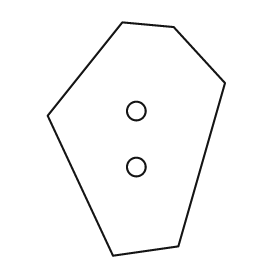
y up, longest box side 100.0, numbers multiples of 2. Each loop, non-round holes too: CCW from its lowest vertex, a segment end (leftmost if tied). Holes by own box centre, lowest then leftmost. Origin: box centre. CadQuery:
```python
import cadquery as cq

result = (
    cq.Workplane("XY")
    .moveTo(-10.0, -50.0)
    .lineTo(18.0, -46.0)
    .lineTo(38.0, 24.0)
    .lineTo(16.0, 48.0)
    .lineTo(-6.0, 50.0)
    .lineTo(-38.0, 10.0)
    .close()
    .moveTo(0.0, -12.0)
    .circle(4.0)
    .moveTo(0.0, 12.0)
    .circle(4.0)
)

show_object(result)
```